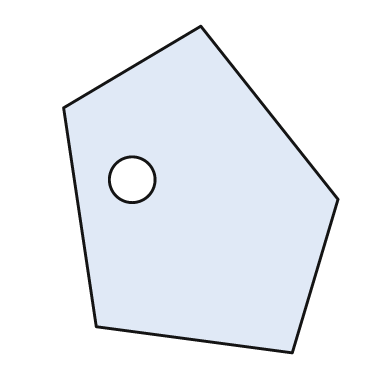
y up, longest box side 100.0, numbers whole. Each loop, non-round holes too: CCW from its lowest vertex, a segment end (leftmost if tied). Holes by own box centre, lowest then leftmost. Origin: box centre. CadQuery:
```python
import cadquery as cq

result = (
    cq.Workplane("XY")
    .moveTo(28.0, -50.0)
    .lineTo(42.0, -3.0)
    .lineTo(0.0, 50.0)
    .lineTo(-42.0, 25.0)
    .lineTo(-32.0, -42.0)
    .close()
    .moveTo(-21.0, 3.0)
    .circle(7.0)
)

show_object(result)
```